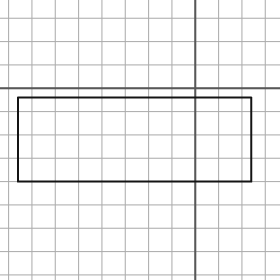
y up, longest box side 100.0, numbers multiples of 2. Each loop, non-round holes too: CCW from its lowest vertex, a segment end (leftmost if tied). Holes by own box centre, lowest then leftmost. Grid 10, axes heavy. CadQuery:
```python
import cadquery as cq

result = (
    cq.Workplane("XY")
    .moveTo(-76.0, -40.0)
    .lineTo(24.0, -40.0)
    .lineTo(24.0, -4.0)
    .lineTo(-76.0, -4.0)
    .close()
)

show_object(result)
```